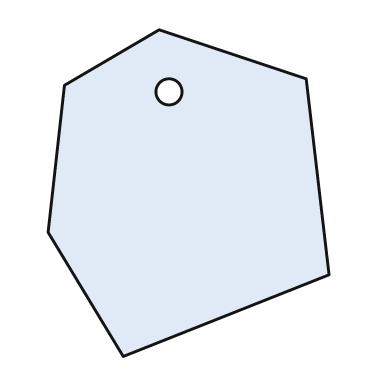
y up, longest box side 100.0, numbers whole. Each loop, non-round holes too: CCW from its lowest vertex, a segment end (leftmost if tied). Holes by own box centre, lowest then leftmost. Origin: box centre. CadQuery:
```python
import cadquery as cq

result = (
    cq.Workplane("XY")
    .moveTo(-20.0, -50.0)
    .lineTo(43.0, -25.0)
    .lineTo(36.0, 35.0)
    .lineTo(-9.0, 50.0)
    .lineTo(-38.0, 33.0)
    .lineTo(-43.0, -12.0)
    .close()
    .moveTo(-6.0, 31.0)
    .circle(4.0)
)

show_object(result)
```